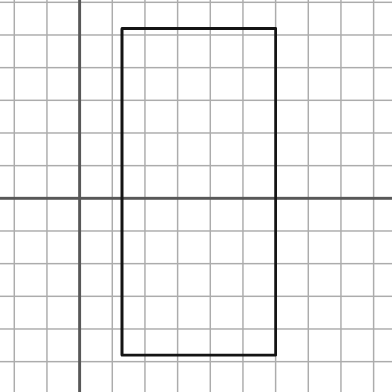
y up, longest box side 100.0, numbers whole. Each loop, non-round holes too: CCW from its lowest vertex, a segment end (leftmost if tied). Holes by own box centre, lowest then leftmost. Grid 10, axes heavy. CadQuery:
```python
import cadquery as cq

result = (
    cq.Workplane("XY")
    .moveTo(13.0, -48.0)
    .lineTo(60.0, -48.0)
    .lineTo(60.0, 52.0)
    .lineTo(13.0, 52.0)
    .close()
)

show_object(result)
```